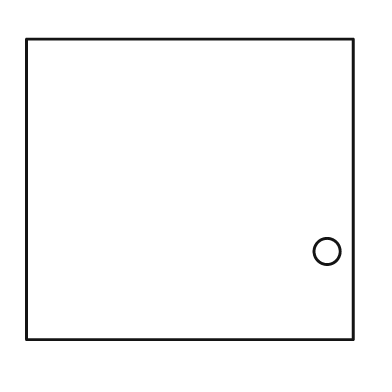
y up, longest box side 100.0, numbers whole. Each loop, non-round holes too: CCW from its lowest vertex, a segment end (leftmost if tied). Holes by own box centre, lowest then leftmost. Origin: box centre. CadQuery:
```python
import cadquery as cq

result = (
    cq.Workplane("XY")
    .moveTo(-50.0, -46.0)
    .lineTo(50.0, -46.0)
    .lineTo(50.0, 46.0)
    .lineTo(-50.0, 46.0)
    .close()
    .moveTo(42.0, -19.0)
    .circle(4.0)
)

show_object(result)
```